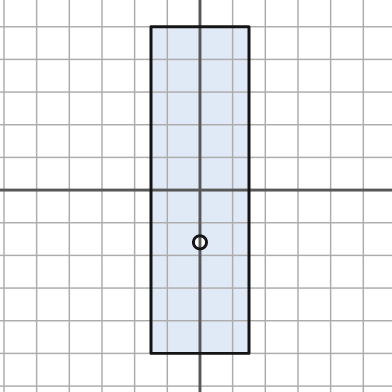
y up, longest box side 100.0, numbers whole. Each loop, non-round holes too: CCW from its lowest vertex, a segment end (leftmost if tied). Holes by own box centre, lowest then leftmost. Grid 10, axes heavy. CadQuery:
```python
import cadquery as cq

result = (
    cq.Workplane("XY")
    .moveTo(-15.0, -50.0)
    .lineTo(15.0, -50.0)
    .lineTo(15.0, 50.0)
    .lineTo(-15.0, 50.0)
    .close()
    .moveTo(0.0, -16.0)
    .circle(2.0)
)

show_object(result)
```